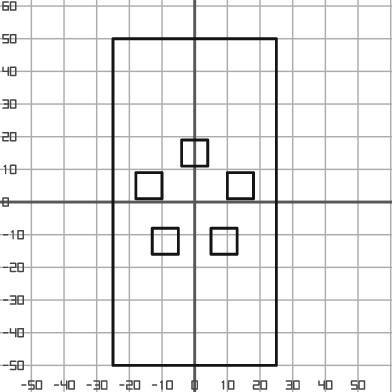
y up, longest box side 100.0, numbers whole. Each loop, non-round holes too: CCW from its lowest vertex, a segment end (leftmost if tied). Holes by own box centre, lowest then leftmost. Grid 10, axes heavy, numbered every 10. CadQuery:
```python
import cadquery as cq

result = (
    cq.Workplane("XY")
    .moveTo(-25.0, -50.0)
    .lineTo(25.0, -50.0)
    .lineTo(25.0, 50.0)
    .lineTo(-25.0, 50.0)
    .close()
    .moveTo(-13.0, -16.0)
    .lineTo(-5.0, -16.0)
    .lineTo(-5.0, -8.0)
    .lineTo(-13.0, -8.0)
    .close()
    .moveTo(5.0, -16.0)
    .lineTo(13.0, -16.0)
    .lineTo(13.0, -8.0)
    .lineTo(5.0, -8.0)
    .close()
    .moveTo(-18.0, 1.0)
    .lineTo(-10.0, 1.0)
    .lineTo(-10.0, 9.0)
    .lineTo(-18.0, 9.0)
    .close()
    .moveTo(10.0, 1.0)
    .lineTo(18.0, 1.0)
    .lineTo(18.0, 9.0)
    .lineTo(10.0, 9.0)
    .close()
    .moveTo(-4.0, 11.0)
    .lineTo(4.0, 11.0)
    .lineTo(4.0, 19.0)
    .lineTo(-4.0, 19.0)
    .close()
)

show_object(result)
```